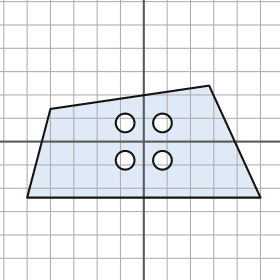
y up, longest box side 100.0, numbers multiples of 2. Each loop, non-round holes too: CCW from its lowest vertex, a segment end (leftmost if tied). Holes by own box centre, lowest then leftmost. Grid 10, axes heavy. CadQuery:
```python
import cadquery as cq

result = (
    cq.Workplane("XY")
    .moveTo(-50.0, -24.0)
    .lineTo(50.0, -24.0)
    .lineTo(28.0, 24.0)
    .lineTo(-40.0, 14.0)
    .close()
    .moveTo(-8.0, -8.0)
    .circle(4.0)
    .moveTo(8.0, -8.0)
    .circle(4.0)
    .moveTo(-8.0, 8.0)
    .circle(4.0)
    .moveTo(8.0, 8.0)
    .circle(4.0)
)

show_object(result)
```